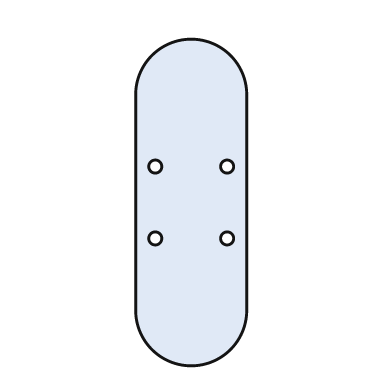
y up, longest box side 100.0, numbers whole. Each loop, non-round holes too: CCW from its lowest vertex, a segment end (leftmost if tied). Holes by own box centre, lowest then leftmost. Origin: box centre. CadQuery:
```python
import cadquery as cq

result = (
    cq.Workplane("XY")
    .moveTo(-17.0, -33.0)
    .threePointArc((0.0, -50.0), (17.0, -33.0))
    .lineTo(17.0, 33.0)
    .threePointArc((0.0, 50.0), (-17.0, 33.0))
    .close()
    .moveTo(-11.0, -11.0)
    .circle(2.0)
    .moveTo(11.0, -11.0)
    .circle(2.0)
    .moveTo(-11.0, 11.0)
    .circle(2.0)
    .moveTo(11.0, 11.0)
    .circle(2.0)
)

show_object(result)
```